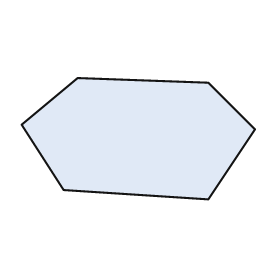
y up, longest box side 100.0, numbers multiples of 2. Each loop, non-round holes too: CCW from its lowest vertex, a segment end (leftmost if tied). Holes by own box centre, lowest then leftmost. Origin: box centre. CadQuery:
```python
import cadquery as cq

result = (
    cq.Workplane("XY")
    .moveTo(30.0, -26.0)
    .lineTo(50.0, 4.0)
    .lineTo(30.0, 24.0)
    .lineTo(-26.0, 26.0)
    .lineTo(-50.0, 6.0)
    .lineTo(-32.0, -22.0)
    .close()
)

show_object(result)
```